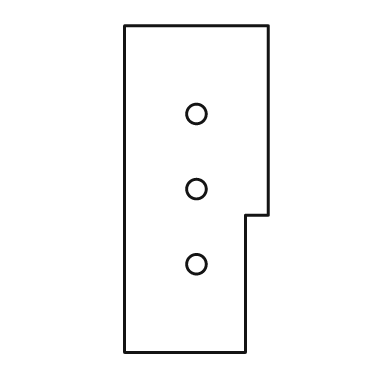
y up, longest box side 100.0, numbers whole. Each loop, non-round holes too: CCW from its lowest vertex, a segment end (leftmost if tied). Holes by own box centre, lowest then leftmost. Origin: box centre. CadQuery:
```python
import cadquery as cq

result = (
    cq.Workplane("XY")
    .moveTo(-22.0, -50.0)
    .lineTo(15.0, -50.0)
    .lineTo(15.0, -8.0)
    .lineTo(22.0, -8.0)
    .lineTo(22.0, 50.0)
    .lineTo(-22.0, 50.0)
    .close()
    .moveTo(0.0, -23.0)
    .circle(3.0)
    .moveTo(0.0, 0.0)
    .circle(3.0)
    .moveTo(0.0, 23.0)
    .circle(3.0)
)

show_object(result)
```